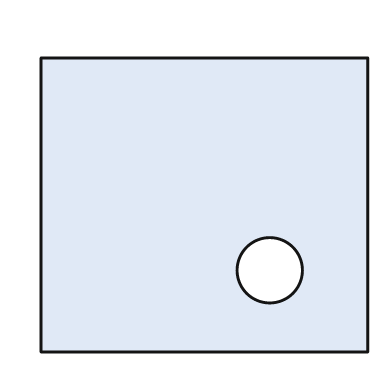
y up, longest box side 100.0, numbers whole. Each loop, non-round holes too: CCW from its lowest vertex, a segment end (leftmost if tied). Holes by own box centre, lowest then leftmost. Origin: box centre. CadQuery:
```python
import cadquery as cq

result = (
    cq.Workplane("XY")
    .moveTo(-50.0, -45.0)
    .lineTo(50.0, -45.0)
    .lineTo(50.0, 45.0)
    .lineTo(-50.0, 45.0)
    .close()
    .moveTo(20.0, -20.0)
    .circle(10.0)
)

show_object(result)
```